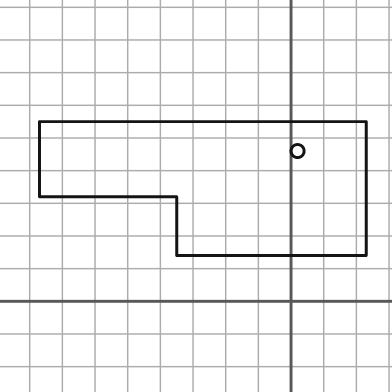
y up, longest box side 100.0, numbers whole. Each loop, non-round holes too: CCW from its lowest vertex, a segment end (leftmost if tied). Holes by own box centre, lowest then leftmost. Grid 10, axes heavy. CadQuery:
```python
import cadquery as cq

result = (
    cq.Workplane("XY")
    .moveTo(-35.0, 14.0)
    .lineTo(23.0, 14.0)
    .lineTo(23.0, 55.0)
    .lineTo(-77.0, 55.0)
    .lineTo(-77.0, 32.0)
    .lineTo(-35.0, 32.0)
    .close()
    .moveTo(2.0, 46.0)
    .circle(2.0)
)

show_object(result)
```